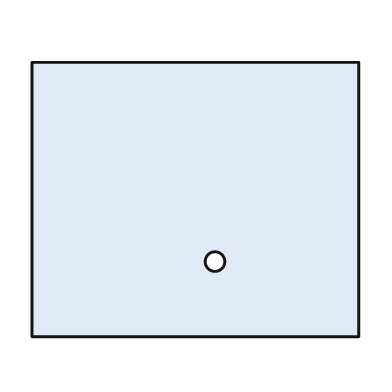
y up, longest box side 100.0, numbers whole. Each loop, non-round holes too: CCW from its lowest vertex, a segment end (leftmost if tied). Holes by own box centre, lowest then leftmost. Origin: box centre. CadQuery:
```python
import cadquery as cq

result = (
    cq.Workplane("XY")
    .moveTo(-50.0, -42.0)
    .lineTo(50.0, -42.0)
    .lineTo(50.0, 42.0)
    .lineTo(-50.0, 42.0)
    .close()
    .moveTo(6.0, -19.0)
    .circle(3.0)
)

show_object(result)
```